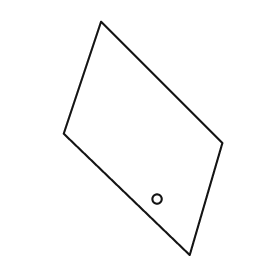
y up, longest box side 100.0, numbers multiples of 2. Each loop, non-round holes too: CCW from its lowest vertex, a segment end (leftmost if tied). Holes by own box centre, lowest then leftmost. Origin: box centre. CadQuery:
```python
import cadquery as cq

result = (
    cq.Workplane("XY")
    .moveTo(20.0, -50.0)
    .lineTo(34.0, -2.0)
    .lineTo(-18.0, 50.0)
    .lineTo(-34.0, 2.0)
    .close()
    .moveTo(6.0, -26.0)
    .circle(2.0)
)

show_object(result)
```